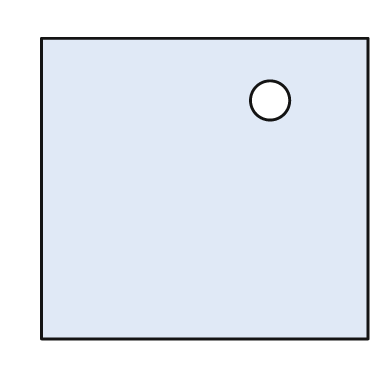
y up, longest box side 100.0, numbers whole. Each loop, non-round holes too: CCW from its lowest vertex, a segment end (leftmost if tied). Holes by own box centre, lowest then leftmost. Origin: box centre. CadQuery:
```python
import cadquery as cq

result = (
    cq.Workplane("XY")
    .moveTo(-50.0, -46.0)
    .lineTo(50.0, -46.0)
    .lineTo(50.0, 46.0)
    .lineTo(-50.0, 46.0)
    .close()
    .moveTo(20.0, 27.0)
    .circle(6.0)
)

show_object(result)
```